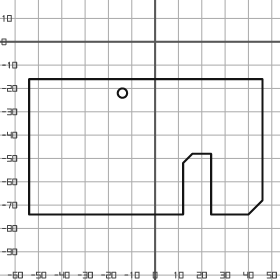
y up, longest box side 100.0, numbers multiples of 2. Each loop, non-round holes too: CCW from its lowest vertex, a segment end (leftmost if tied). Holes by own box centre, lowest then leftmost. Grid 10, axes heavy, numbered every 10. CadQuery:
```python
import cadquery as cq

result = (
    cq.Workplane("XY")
    .moveTo(-54.0, -74.0)
    .lineTo(12.0, -74.0)
    .lineTo(12.0, -52.0)
    .lineTo(16.0, -48.0)
    .lineTo(24.0, -48.0)
    .lineTo(24.0, -74.0)
    .lineTo(40.0, -74.0)
    .lineTo(46.0, -68.0)
    .lineTo(46.0, -16.0)
    .lineTo(-54.0, -16.0)
    .close()
    .moveTo(-14.0, -22.0)
    .circle(2.0)
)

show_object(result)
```